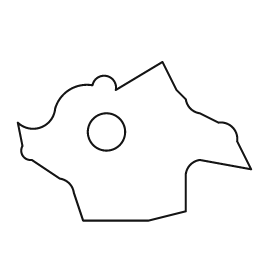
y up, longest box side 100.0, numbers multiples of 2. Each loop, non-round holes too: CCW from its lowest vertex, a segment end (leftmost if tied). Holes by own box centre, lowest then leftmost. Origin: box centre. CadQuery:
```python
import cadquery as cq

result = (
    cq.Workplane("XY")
    .moveTo(-22.0, -34.0)
    .lineTo(6.0, -34.0)
    .lineTo(22.0, -30.0)
    .lineTo(22.0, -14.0)
    .threePointArc((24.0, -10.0), (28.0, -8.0))
    .lineTo(50.0, -12.0)
    .lineTo(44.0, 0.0)
    .threePointArc((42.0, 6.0), (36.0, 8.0))
    .lineTo(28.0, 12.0)
    .threePointArc((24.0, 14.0), (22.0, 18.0))
    .lineTo(18.0, 22.0)
    .lineTo(12.0, 34.0)
    .lineTo(-8.0, 22.0)
    .threePointArc((-12.0, 28.0), (-18.0, 24.0))
    .threePointArc((-28.0, 22.0), (-34.0, 14.0))
    .threePointArc((-40.0, 6.0), (-50.0, 8.0))
    .lineTo(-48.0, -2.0)
    .threePointArc((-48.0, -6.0), (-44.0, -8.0))
    .lineTo(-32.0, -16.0)
    .threePointArc((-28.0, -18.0), (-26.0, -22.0))
    .close()
    .moveTo(-12.0, 4.0)
    .circle(8.0)
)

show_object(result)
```